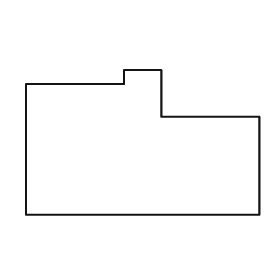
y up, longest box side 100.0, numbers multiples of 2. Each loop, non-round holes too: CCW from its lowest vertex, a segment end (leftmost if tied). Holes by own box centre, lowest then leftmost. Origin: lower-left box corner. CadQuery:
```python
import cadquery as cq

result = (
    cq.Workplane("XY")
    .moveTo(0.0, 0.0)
    .lineTo(100.0, 0.0)
    .lineTo(100.0, 42.0)
    .lineTo(58.0, 42.0)
    .lineTo(58.0, 62.0)
    .lineTo(42.0, 62.0)
    .lineTo(42.0, 56.0)
    .lineTo(0.0, 56.0)
    .close()
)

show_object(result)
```